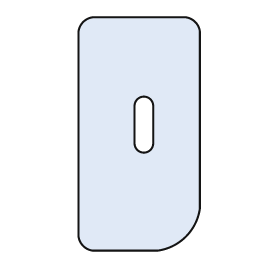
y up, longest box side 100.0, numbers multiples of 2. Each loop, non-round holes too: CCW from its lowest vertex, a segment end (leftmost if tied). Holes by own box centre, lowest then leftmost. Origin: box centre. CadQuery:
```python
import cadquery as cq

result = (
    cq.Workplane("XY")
    .moveTo(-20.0, -50.0)
    .lineTo(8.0, -50.0)
    .threePointArc((20.0, -44.0), (26.0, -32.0))
    .lineTo(26.0, 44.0)
    .threePointArc((24.0, 48.0), (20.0, 50.0))
    .lineTo(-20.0, 50.0)
    .threePointArc((-24.0, 48.0), (-26.0, 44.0))
    .lineTo(-26.0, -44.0)
    .threePointArc((-24.0, -48.0), (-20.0, -50.0))
    .close()
    .moveTo(-2.0, -4.0)
    .threePointArc((2.0, -8.0), (6.0, -4.0))
    .lineTo(6.0, 12.0)
    .threePointArc((2.0, 16.0), (-2.0, 12.0))
    .close()
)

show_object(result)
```